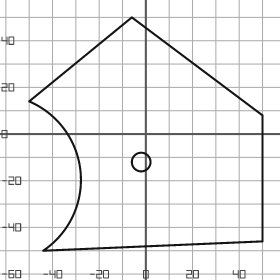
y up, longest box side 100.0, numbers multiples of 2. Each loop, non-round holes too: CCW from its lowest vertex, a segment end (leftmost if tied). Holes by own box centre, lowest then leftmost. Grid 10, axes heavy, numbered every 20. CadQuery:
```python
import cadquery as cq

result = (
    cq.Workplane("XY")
    .moveTo(-44.0, -50.0)
    .lineTo(50.0, -46.0)
    .lineTo(50.0, 8.0)
    .lineTo(-6.0, 50.0)
    .lineTo(-50.0, 14.0)
    .threePointArc((-28.0, -16.0), (-44.0, -50.0))
    .close()
    .moveTo(-2.0, -12.0)
    .circle(4.0)
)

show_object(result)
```